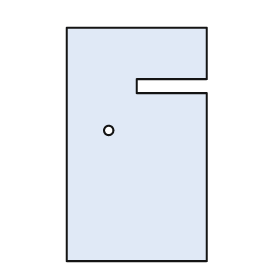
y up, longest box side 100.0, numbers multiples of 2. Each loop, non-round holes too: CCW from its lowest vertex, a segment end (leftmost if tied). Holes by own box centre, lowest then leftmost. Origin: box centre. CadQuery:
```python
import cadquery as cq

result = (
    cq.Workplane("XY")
    .moveTo(-30.0, -50.0)
    .lineTo(30.0, -50.0)
    .lineTo(30.0, 22.0)
    .lineTo(0.0, 22.0)
    .lineTo(0.0, 28.0)
    .lineTo(30.0, 28.0)
    .lineTo(30.0, 50.0)
    .lineTo(-30.0, 50.0)
    .close()
    .moveTo(-12.0, 6.0)
    .circle(2.0)
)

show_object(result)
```